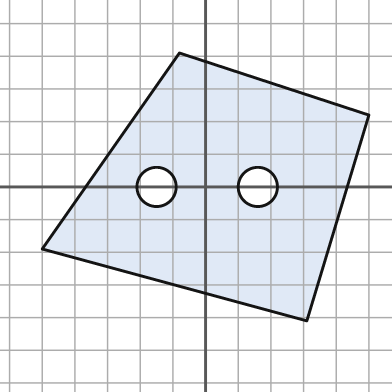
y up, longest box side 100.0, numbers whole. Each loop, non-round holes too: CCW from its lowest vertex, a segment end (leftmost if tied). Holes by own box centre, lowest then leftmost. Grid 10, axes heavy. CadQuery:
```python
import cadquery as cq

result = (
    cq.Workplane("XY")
    .moveTo(31.0, -41.0)
    .lineTo(50.0, 22.0)
    .lineTo(-8.0, 41.0)
    .lineTo(-50.0, -19.0)
    .close()
    .moveTo(-15.0, 0.0)
    .circle(6.0)
    .moveTo(16.0, 0.0)
    .circle(6.0)
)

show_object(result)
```